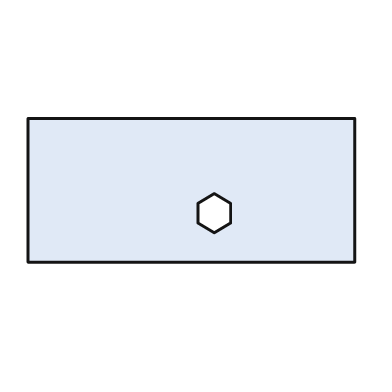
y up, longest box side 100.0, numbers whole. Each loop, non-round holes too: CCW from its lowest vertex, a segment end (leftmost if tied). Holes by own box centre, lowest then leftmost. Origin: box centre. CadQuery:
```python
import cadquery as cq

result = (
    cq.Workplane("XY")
    .moveTo(-50.0, -22.0)
    .lineTo(50.0, -22.0)
    .lineTo(50.0, 22.0)
    .lineTo(-50.0, 22.0)
    .close()
    .moveTo(7.0, -13.0)
    .lineTo(12.0, -10.0)
    .lineTo(12.0, -4.0)
    .lineTo(7.0, -1.0)
    .lineTo(2.0, -4.0)
    .lineTo(2.0, -10.0)
    .close()
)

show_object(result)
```